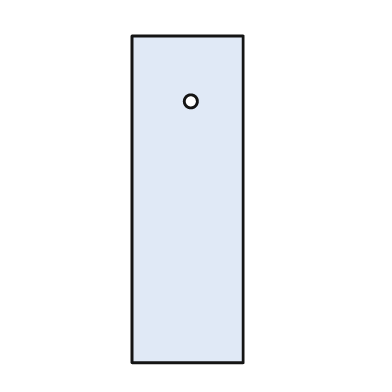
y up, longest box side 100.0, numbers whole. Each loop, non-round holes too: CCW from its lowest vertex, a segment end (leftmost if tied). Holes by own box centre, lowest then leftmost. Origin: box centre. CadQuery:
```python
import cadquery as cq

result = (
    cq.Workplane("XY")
    .moveTo(-17.0, -50.0)
    .lineTo(17.0, -50.0)
    .lineTo(17.0, 50.0)
    .lineTo(-17.0, 50.0)
    .close()
    .moveTo(1.0, 30.0)
    .circle(2.0)
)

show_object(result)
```